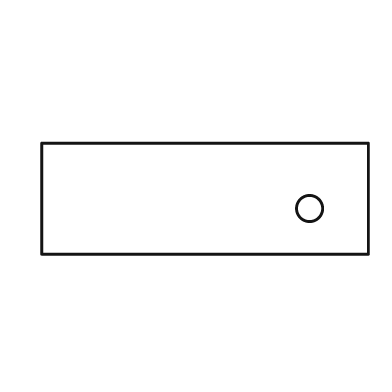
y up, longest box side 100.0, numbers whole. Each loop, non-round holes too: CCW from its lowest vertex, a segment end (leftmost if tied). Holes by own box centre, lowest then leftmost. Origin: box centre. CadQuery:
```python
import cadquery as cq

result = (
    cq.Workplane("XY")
    .moveTo(-50.0, -17.0)
    .lineTo(50.0, -17.0)
    .lineTo(50.0, 17.0)
    .lineTo(-50.0, 17.0)
    .close()
    .moveTo(32.0, -3.0)
    .circle(4.0)
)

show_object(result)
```